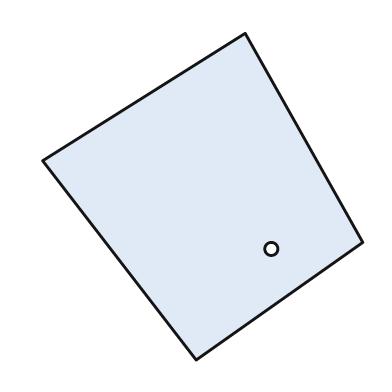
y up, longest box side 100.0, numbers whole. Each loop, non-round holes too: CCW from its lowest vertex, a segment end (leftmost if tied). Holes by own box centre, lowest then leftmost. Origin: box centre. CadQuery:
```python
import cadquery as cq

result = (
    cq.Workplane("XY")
    .moveTo(-2.0, -50.0)
    .lineTo(49.0, -14.0)
    .lineTo(13.0, 50.0)
    .lineTo(-49.0, 11.0)
    .close()
    .moveTo(21.0, -16.0)
    .circle(2.0)
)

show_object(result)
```